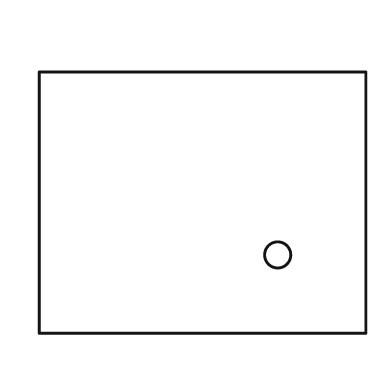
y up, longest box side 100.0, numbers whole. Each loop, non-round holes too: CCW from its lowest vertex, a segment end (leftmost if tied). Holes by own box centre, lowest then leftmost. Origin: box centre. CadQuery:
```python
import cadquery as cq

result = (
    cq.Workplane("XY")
    .moveTo(-50.0, -40.0)
    .lineTo(50.0, -40.0)
    .lineTo(50.0, 40.0)
    .lineTo(-50.0, 40.0)
    .close()
    .moveTo(23.0, -16.0)
    .circle(4.0)
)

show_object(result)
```